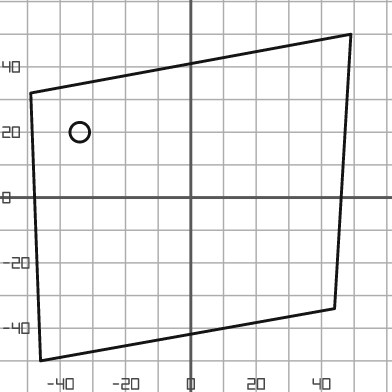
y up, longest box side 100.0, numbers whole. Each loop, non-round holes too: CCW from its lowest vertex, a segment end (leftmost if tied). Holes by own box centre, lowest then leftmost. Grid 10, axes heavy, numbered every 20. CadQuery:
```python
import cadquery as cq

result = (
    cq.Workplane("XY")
    .moveTo(-46.0, -50.0)
    .lineTo(44.0, -34.0)
    .lineTo(49.0, 50.0)
    .lineTo(-49.0, 32.0)
    .close()
    .moveTo(-34.0, 20.0)
    .circle(3.0)
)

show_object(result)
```